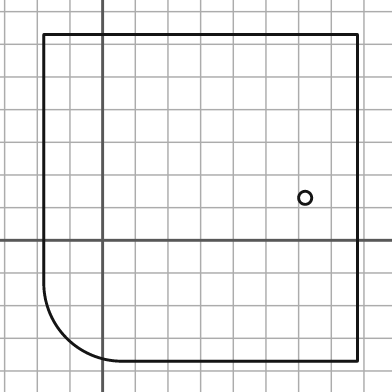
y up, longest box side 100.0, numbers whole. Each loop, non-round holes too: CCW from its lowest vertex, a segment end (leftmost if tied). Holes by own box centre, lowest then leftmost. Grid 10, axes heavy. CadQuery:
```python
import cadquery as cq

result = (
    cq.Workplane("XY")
    .moveTo(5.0, -37.0)
    .lineTo(78.0, -37.0)
    .lineTo(78.0, 63.0)
    .lineTo(-18.0, 63.0)
    .lineTo(-18.0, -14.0)
    .threePointArc((-11.0, -30.0), (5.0, -37.0))
    .close()
    .moveTo(62.0, 13.0)
    .circle(2.0)
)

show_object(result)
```